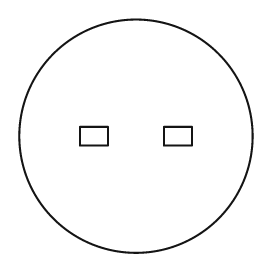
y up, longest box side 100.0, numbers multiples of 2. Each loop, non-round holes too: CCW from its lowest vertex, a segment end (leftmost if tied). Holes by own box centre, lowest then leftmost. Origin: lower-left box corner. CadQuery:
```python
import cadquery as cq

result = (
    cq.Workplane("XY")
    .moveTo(50.0, 50.0)
    .circle(50.0)
    .moveTo(26.0, 46.0)
    .lineTo(38.0, 46.0)
    .lineTo(38.0, 54.0)
    .lineTo(26.0, 54.0)
    .close()
    .moveTo(62.0, 46.0)
    .lineTo(74.0, 46.0)
    .lineTo(74.0, 54.0)
    .lineTo(62.0, 54.0)
    .close()
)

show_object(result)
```